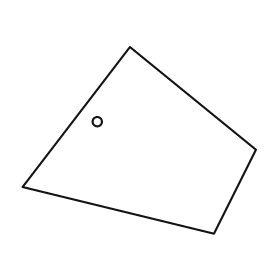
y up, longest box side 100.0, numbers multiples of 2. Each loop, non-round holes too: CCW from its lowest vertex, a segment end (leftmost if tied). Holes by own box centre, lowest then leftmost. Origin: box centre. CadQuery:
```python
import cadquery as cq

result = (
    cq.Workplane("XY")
    .moveTo(32.0, -40.0)
    .lineTo(50.0, -4.0)
    .lineTo(-4.0, 40.0)
    .lineTo(-50.0, -20.0)
    .close()
    .moveTo(-18.0, 8.0)
    .circle(2.0)
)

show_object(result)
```